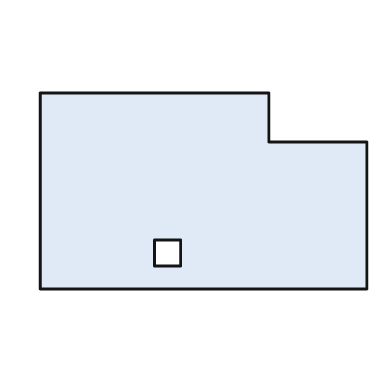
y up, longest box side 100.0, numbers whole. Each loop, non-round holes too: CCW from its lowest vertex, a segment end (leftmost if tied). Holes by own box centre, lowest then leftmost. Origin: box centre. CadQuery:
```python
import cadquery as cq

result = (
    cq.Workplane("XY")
    .moveTo(-50.0, -30.0)
    .lineTo(50.0, -30.0)
    .lineTo(50.0, 15.0)
    .lineTo(20.0, 15.0)
    .lineTo(20.0, 30.0)
    .lineTo(-50.0, 30.0)
    .close()
    .moveTo(-15.0, -23.0)
    .lineTo(-7.0, -23.0)
    .lineTo(-7.0, -15.0)
    .lineTo(-15.0, -15.0)
    .close()
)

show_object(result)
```